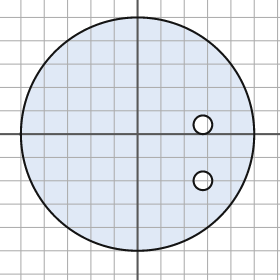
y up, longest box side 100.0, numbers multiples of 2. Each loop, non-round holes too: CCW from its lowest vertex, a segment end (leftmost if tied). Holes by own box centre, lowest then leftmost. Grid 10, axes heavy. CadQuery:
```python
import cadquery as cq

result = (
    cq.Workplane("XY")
    .moveTo(0.0, 0.0)
    .circle(50.0)
    .moveTo(28.0, -20.0)
    .circle(4.0)
    .moveTo(28.0, 4.0)
    .circle(4.0)
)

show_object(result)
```